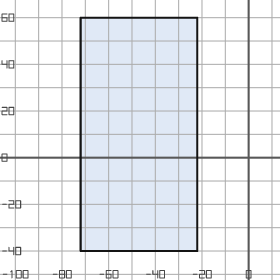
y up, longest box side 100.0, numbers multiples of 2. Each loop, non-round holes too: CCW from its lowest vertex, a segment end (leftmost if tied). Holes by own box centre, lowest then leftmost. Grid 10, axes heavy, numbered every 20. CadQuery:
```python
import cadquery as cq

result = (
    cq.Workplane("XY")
    .moveTo(-72.0, -40.0)
    .lineTo(-22.0, -40.0)
    .lineTo(-22.0, 60.0)
    .lineTo(-72.0, 60.0)
    .close()
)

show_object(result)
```